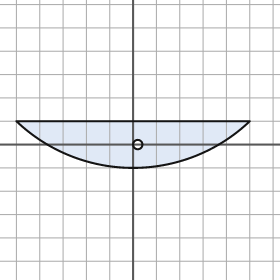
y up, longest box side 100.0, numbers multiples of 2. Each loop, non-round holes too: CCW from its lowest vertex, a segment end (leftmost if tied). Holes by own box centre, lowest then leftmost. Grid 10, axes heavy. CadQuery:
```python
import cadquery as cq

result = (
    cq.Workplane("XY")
    .moveTo(-50.0, 10.0)
    .threePointArc((0.0, -10.0), (50.0, 10.0))
    .close()
    .moveTo(2.0, 0.0)
    .circle(2.0)
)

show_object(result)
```